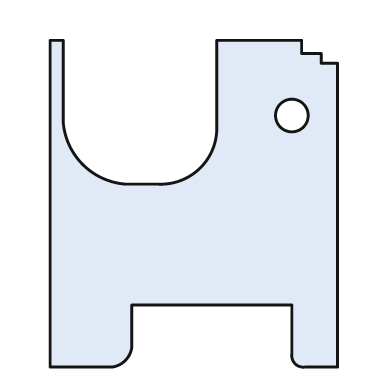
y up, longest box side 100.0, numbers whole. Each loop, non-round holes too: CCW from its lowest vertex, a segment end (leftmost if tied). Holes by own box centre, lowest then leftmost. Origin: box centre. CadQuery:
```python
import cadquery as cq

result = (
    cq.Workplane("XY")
    .moveTo(-44.0, -50.0)
    .lineTo(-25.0, -50.0)
    .threePointArc((-21.0, -48.0), (-19.0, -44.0))
    .lineTo(-19.0, -31.0)
    .lineTo(30.0, -31.0)
    .lineTo(30.0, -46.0)
    .threePointArc((31.0, -49.0), (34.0, -50.0))
    .lineTo(44.0, -50.0)
    .lineTo(44.0, 43.0)
    .lineTo(39.0, 43.0)
    .lineTo(39.0, 46.0)
    .lineTo(33.0, 46.0)
    .lineTo(33.0, 50.0)
    .lineTo(7.0, 50.0)
    .lineTo(7.0, 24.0)
    .threePointArc((2.0, 11.0), (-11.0, 6.0))
    .lineTo(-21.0, 6.0)
    .threePointArc((-34.0, 12.0), (-40.0, 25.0))
    .lineTo(-40.0, 50.0)
    .lineTo(-44.0, 50.0)
    .close()
    .moveTo(30.0, 27.0)
    .circle(5.0)
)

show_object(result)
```